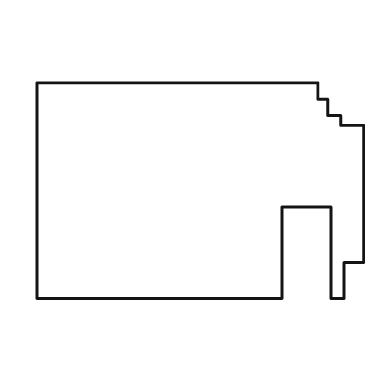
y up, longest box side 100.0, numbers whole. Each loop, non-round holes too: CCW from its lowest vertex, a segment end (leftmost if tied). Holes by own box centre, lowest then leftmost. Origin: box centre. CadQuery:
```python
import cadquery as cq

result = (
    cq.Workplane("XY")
    .moveTo(-50.0, -33.0)
    .lineTo(25.0, -33.0)
    .lineTo(25.0, -5.0)
    .lineTo(40.0, -5.0)
    .lineTo(40.0, -33.0)
    .lineTo(44.0, -33.0)
    .lineTo(44.0, -22.0)
    .lineTo(50.0, -22.0)
    .lineTo(50.0, 20.0)
    .lineTo(43.0, 20.0)
    .lineTo(43.0, 23.0)
    .lineTo(39.0, 23.0)
    .lineTo(39.0, 28.0)
    .lineTo(36.0, 28.0)
    .lineTo(36.0, 33.0)
    .lineTo(-50.0, 33.0)
    .close()
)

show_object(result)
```